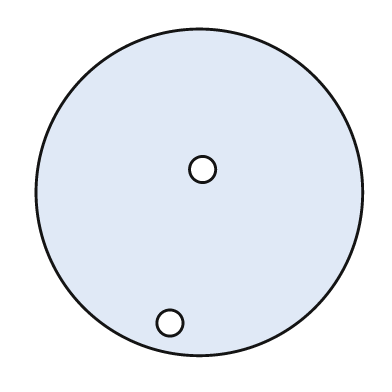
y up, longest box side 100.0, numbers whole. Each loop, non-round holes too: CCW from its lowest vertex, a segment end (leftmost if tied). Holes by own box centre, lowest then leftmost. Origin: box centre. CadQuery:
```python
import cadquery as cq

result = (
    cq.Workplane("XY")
    .moveTo(0.0, 0.0)
    .circle(50.0)
    .moveTo(-9.0, -40.0)
    .circle(4.0)
    .moveTo(1.0, 7.0)
    .circle(4.0)
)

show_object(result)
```